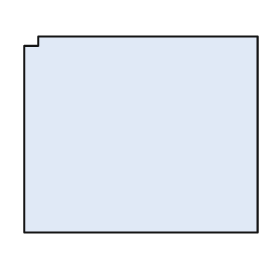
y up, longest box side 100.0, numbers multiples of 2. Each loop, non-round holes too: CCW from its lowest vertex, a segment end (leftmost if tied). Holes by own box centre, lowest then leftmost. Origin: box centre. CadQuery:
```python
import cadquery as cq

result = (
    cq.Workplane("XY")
    .moveTo(-50.0, -42.0)
    .lineTo(50.0, -42.0)
    .lineTo(50.0, 42.0)
    .lineTo(-44.0, 42.0)
    .lineTo(-44.0, 38.0)
    .lineTo(-50.0, 38.0)
    .close()
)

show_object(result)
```